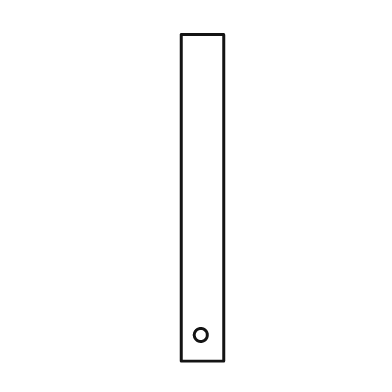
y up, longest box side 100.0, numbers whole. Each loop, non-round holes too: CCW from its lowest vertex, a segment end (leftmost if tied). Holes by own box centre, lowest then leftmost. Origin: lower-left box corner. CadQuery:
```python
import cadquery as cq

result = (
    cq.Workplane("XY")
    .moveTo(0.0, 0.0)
    .lineTo(13.0, 0.0)
    .lineTo(13.0, 100.0)
    .lineTo(0.0, 100.0)
    .close()
    .moveTo(6.0, 8.0)
    .circle(2.0)
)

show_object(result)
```